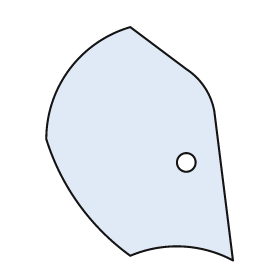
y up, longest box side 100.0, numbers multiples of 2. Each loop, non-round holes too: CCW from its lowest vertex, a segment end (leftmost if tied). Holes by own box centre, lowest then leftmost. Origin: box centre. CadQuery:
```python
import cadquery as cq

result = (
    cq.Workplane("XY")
    .moveTo(40.0, -50.0)
    .lineTo(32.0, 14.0)
    .threePointArc((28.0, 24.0), (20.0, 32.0))
    .lineTo(-4.0, 50.0)
    .threePointArc((-30.0, 32.0), (-40.0, 2.0))
    .threePointArc((-26.0, -26.0), (-4.0, -48.0))
    .threePointArc((18.0, -44.0), (40.0, -50.0))
    .close()
    .moveTo(20.0, -8.0)
    .circle(4.0)
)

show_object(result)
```